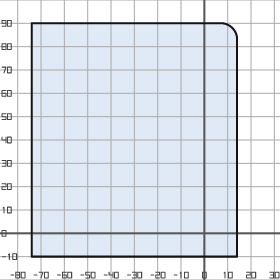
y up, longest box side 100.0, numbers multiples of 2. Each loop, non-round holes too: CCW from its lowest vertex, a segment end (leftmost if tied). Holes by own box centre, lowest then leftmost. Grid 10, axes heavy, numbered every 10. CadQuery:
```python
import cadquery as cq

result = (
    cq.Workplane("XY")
    .moveTo(-74.0, -10.0)
    .lineTo(14.0, -10.0)
    .lineTo(14.0, 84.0)
    .threePointArc((12.0, 88.0), (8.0, 90.0))
    .lineTo(-74.0, 90.0)
    .close()
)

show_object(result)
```